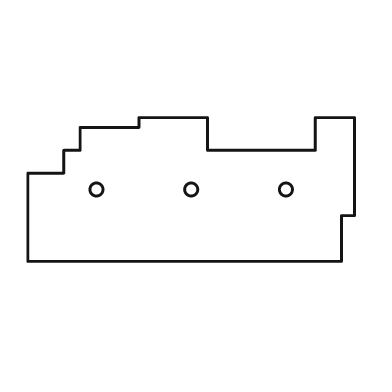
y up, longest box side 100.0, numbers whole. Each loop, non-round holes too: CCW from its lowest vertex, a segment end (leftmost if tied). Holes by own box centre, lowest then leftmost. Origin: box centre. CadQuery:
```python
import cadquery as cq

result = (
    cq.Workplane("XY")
    .moveTo(-50.0, -22.0)
    .lineTo(46.0, -22.0)
    .lineTo(46.0, -8.0)
    .lineTo(50.0, -8.0)
    .lineTo(50.0, 22.0)
    .lineTo(38.0, 22.0)
    .lineTo(38.0, 12.0)
    .lineTo(5.0, 12.0)
    .lineTo(5.0, 22.0)
    .lineTo(-16.0, 22.0)
    .lineTo(-16.0, 19.0)
    .lineTo(-34.0, 19.0)
    .lineTo(-34.0, 12.0)
    .lineTo(-39.0, 12.0)
    .lineTo(-39.0, 5.0)
    .lineTo(-50.0, 5.0)
    .close()
    .moveTo(-29.0, 0.0)
    .circle(2.0)
    .moveTo(0.0, 0.0)
    .circle(2.0)
    .moveTo(29.0, 0.0)
    .circle(2.0)
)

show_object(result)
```